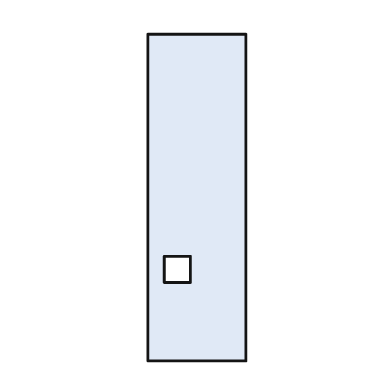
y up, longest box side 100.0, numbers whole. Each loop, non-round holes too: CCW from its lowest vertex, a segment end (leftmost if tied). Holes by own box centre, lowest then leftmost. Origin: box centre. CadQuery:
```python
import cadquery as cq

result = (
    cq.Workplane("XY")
    .moveTo(-15.0, -50.0)
    .lineTo(15.0, -50.0)
    .lineTo(15.0, 50.0)
    .lineTo(-15.0, 50.0)
    .close()
    .moveTo(-10.0, -26.0)
    .lineTo(-2.0, -26.0)
    .lineTo(-2.0, -18.0)
    .lineTo(-10.0, -18.0)
    .close()
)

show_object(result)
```